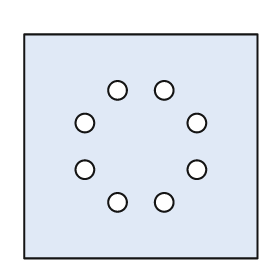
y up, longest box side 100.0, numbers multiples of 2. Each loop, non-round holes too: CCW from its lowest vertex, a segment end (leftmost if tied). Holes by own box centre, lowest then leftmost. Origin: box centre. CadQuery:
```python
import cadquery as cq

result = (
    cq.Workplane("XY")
    .moveTo(-50.0, -48.0)
    .lineTo(50.0, -48.0)
    .lineTo(50.0, 48.0)
    .lineTo(-50.0, 48.0)
    .close()
    .moveTo(-10.0, -24.0)
    .circle(4.0)
    .moveTo(10.0, -24.0)
    .circle(4.0)
    .moveTo(-24.0, -10.0)
    .circle(4.0)
    .moveTo(24.0, -10.0)
    .circle(4.0)
    .moveTo(-24.0, 10.0)
    .circle(4.0)
    .moveTo(24.0, 10.0)
    .circle(4.0)
    .moveTo(-10.0, 24.0)
    .circle(4.0)
    .moveTo(10.0, 24.0)
    .circle(4.0)
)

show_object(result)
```